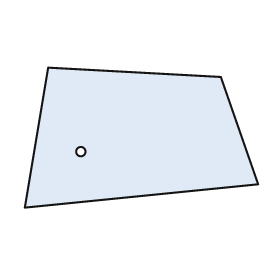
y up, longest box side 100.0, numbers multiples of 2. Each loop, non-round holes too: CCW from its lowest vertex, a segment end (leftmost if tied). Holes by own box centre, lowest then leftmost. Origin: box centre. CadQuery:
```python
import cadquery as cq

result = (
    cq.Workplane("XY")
    .moveTo(-50.0, -30.0)
    .lineTo(50.0, -20.0)
    .lineTo(34.0, 26.0)
    .lineTo(-40.0, 30.0)
    .close()
    .moveTo(-26.0, -6.0)
    .circle(2.0)
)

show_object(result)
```